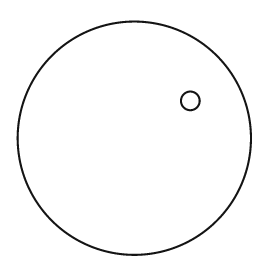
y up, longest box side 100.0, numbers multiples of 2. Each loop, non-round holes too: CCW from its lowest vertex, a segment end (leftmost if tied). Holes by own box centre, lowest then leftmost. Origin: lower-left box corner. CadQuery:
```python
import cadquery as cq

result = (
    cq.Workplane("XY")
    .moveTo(50.0, 50.0)
    .circle(50.0)
    .moveTo(74.0, 66.0)
    .circle(4.0)
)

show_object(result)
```